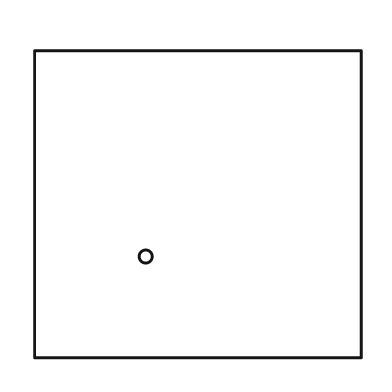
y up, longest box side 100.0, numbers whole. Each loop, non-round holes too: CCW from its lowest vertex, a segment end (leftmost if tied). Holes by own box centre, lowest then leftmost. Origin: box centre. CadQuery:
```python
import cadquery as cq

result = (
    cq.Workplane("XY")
    .moveTo(-50.0, -47.0)
    .lineTo(50.0, -47.0)
    .lineTo(50.0, 47.0)
    .lineTo(-50.0, 47.0)
    .close()
    .moveTo(-16.0, -16.0)
    .circle(2.0)
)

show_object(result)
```